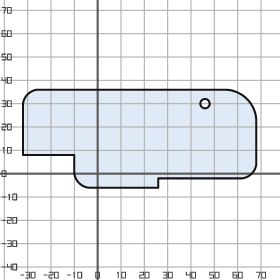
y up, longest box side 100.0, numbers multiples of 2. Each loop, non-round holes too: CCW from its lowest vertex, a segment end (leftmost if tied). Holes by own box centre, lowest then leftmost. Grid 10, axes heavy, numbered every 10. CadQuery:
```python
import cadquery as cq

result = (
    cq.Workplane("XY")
    .moveTo(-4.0, -6.0)
    .lineTo(26.0, -6.0)
    .lineTo(26.0, -2.0)
    .lineTo(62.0, -2.0)
    .threePointArc((66.0, 0.0), (68.0, 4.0))
    .lineTo(68.0, 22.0)
    .threePointArc((64.0, 32.0), (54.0, 36.0))
    .lineTo(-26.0, 36.0)
    .threePointArc((-30.0, 34.0), (-32.0, 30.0))
    .lineTo(-32.0, 8.0)
    .lineTo(-10.0, 8.0)
    .lineTo(-10.0, 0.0)
    .threePointArc((-8.0, -4.0), (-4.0, -6.0))
    .close()
    .moveTo(46.0, 30.0)
    .circle(2.0)
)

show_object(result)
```